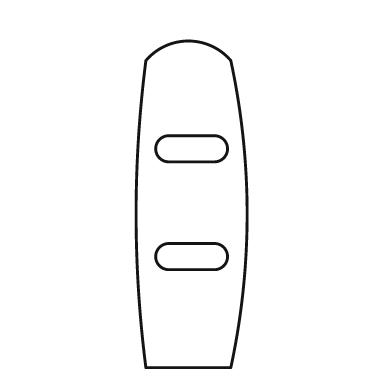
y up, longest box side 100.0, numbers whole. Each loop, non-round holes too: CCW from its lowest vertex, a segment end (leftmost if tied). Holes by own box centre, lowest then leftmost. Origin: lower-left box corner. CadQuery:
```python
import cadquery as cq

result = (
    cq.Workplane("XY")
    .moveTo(3.0, 0.0)
    .lineTo(29.0, 0.0)
    .threePointArc((34.0, 47.0), (29.0, 94.0))
    .threePointArc((16.0, 100.0), (3.0, 94.0))
    .threePointArc((0.0, 47.0), (3.0, 0.0))
    .close()
    .moveTo(10.0, 30.0)
    .lineTo(24.0, 30.0)
    .threePointArc((28.0, 34.0), (24.0, 38.0))
    .lineTo(10.0, 38.0)
    .threePointArc((6.0, 34.0), (10.0, 30.0))
    .close()
    .moveTo(10.0, 63.0)
    .lineTo(24.0, 63.0)
    .threePointArc((28.0, 67.0), (24.0, 71.0))
    .lineTo(10.0, 71.0)
    .threePointArc((6.0, 67.0), (10.0, 63.0))
    .close()
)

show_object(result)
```